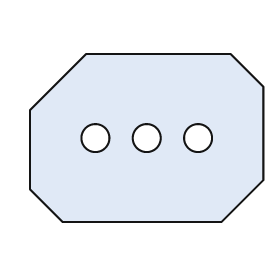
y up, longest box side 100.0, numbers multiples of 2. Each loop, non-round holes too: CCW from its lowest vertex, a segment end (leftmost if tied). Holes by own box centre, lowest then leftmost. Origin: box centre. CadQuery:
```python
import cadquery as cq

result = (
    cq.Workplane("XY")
    .moveTo(-36.0, -36.0)
    .lineTo(32.0, -36.0)
    .lineTo(50.0, -18.0)
    .lineTo(50.0, 22.0)
    .lineTo(36.0, 36.0)
    .lineTo(-26.0, 36.0)
    .lineTo(-50.0, 12.0)
    .lineTo(-50.0, -22.0)
    .close()
    .moveTo(-22.0, 0.0)
    .circle(6.0)
    .moveTo(0.0, 0.0)
    .circle(6.0)
    .moveTo(22.0, 0.0)
    .circle(6.0)
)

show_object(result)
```